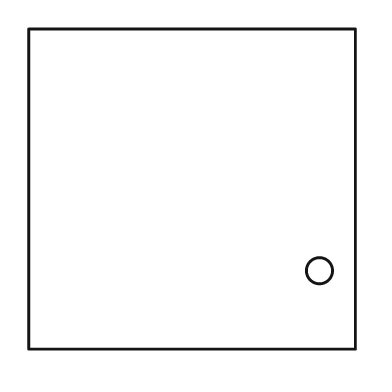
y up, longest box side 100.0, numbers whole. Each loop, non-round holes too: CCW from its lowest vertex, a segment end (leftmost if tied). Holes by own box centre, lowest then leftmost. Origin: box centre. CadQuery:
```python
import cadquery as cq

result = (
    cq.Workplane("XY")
    .moveTo(-50.0, -49.0)
    .lineTo(50.0, -49.0)
    .lineTo(50.0, 49.0)
    .lineTo(-50.0, 49.0)
    .close()
    .moveTo(39.0, -25.0)
    .circle(4.0)
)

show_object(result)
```